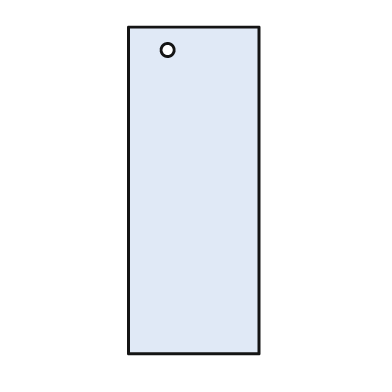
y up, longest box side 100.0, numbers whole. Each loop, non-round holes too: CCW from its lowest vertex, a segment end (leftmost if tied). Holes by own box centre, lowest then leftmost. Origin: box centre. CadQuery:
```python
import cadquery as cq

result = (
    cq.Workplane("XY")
    .moveTo(-20.0, -50.0)
    .lineTo(20.0, -50.0)
    .lineTo(20.0, 50.0)
    .lineTo(-20.0, 50.0)
    .close()
    .moveTo(-8.0, 43.0)
    .circle(2.0)
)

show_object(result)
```